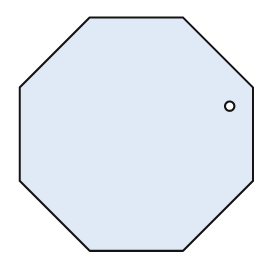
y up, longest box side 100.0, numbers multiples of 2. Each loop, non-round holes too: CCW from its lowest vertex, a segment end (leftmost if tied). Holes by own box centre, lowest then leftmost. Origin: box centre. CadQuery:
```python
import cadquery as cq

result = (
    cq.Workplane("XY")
    .moveTo(-20.0, -50.0)
    .lineTo(20.0, -50.0)
    .lineTo(50.0, -20.0)
    .lineTo(50.0, 20.0)
    .lineTo(20.0, 50.0)
    .lineTo(-20.0, 50.0)
    .lineTo(-50.0, 20.0)
    .lineTo(-50.0, -20.0)
    .close()
    .moveTo(40.0, 12.0)
    .circle(2.0)
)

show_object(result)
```